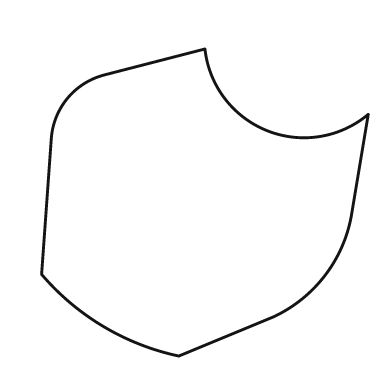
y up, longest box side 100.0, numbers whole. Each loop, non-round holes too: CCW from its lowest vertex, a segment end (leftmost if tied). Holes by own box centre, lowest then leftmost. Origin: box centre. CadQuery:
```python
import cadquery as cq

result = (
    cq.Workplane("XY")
    .moveTo(-8.0, -47.0)
    .lineTo(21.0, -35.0)
    .threePointArc((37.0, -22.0), (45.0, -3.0))
    .lineTo(50.0, 27.0)
    .threePointArc((19.0, 22.0), (0.0, 47.0))
    .lineTo(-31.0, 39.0)
    .threePointArc((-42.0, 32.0), (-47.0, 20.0))
    .lineTo(-50.0, -22.0)
    .threePointArc((-31.0, -38.0), (-8.0, -47.0))
    .close()
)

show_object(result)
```